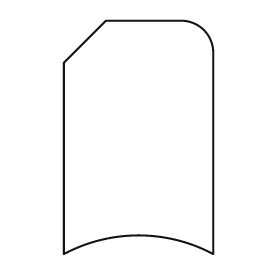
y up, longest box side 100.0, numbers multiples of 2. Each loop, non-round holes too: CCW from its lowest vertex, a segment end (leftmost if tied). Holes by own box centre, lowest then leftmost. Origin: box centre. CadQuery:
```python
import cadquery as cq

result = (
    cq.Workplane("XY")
    .moveTo(-32.0, -50.0)
    .threePointArc((0.0, -42.0), (32.0, -50.0))
    .lineTo(32.0, 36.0)
    .threePointArc((28.0, 46.0), (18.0, 50.0))
    .lineTo(-14.0, 50.0)
    .lineTo(-32.0, 32.0)
    .close()
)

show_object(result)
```